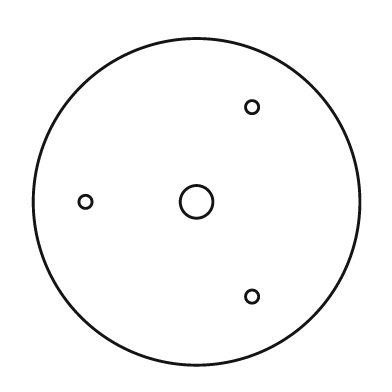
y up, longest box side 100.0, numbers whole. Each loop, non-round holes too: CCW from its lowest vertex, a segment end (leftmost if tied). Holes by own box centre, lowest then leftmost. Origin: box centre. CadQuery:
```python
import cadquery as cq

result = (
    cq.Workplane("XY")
    .moveTo(0.0, 0.0)
    .circle(50.0)
    .moveTo(17.0, -29.0)
    .circle(2.0)
    .moveTo(-34.0, 0.0)
    .circle(2.0)
    .moveTo(0.0, 0.0)
    .circle(5.0)
    .moveTo(17.0, 29.0)
    .circle(2.0)
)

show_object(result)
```